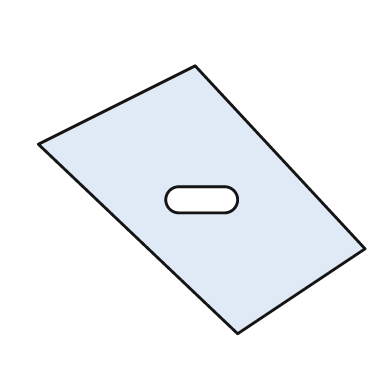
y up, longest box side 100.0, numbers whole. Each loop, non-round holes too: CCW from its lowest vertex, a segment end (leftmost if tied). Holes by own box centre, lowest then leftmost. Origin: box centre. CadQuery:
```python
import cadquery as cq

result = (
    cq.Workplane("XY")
    .moveTo(11.0, -41.0)
    .lineTo(50.0, -15.0)
    .lineTo(-2.0, 41.0)
    .lineTo(-50.0, 17.0)
    .close()
    .moveTo(-7.0, -4.0)
    .lineTo(7.0, -4.0)
    .threePointArc((11.0, 0.0), (7.0, 4.0))
    .lineTo(-7.0, 4.0)
    .threePointArc((-11.0, 0.0), (-7.0, -4.0))
    .close()
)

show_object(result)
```